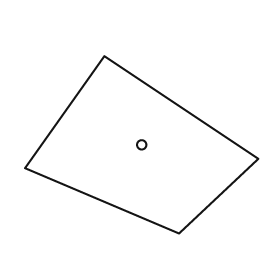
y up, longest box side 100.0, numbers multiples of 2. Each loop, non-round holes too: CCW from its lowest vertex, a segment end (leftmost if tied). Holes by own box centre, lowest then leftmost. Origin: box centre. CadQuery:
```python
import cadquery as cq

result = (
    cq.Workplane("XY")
    .moveTo(16.0, -38.0)
    .lineTo(50.0, -6.0)
    .lineTo(-16.0, 38.0)
    .lineTo(-50.0, -10.0)
    .close()
    .moveTo(0.0, 0.0)
    .circle(2.0)
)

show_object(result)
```